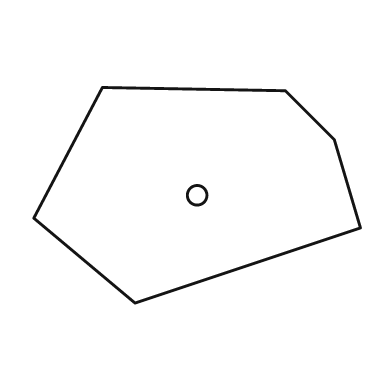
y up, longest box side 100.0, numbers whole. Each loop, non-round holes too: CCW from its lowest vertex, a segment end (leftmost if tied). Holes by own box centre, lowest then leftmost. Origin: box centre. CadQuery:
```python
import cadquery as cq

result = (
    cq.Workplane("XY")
    .moveTo(-19.0, -33.0)
    .lineTo(50.0, -10.0)
    .lineTo(42.0, 17.0)
    .lineTo(27.0, 32.0)
    .lineTo(-29.0, 33.0)
    .lineTo(-50.0, -7.0)
    .close()
    .moveTo(0.0, 0.0)
    .circle(3.0)
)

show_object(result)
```